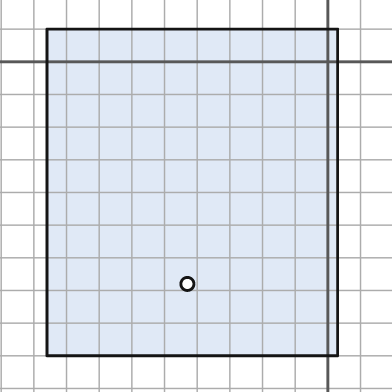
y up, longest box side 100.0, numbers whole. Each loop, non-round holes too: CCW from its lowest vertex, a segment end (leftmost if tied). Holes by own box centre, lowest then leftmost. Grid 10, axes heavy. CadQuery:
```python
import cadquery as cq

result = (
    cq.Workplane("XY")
    .moveTo(-86.0, -90.0)
    .lineTo(3.0, -90.0)
    .lineTo(3.0, 10.0)
    .lineTo(-86.0, 10.0)
    .close()
    .moveTo(-43.0, -68.0)
    .circle(2.0)
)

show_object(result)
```